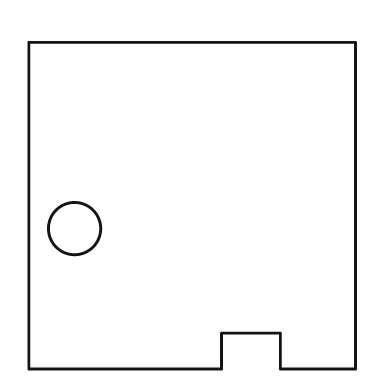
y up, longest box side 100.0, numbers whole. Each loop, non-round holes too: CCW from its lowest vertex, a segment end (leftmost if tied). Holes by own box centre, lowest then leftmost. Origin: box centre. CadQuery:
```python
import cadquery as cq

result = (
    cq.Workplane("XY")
    .moveTo(-50.0, -50.0)
    .lineTo(9.0, -50.0)
    .lineTo(9.0, -39.0)
    .lineTo(27.0, -39.0)
    .lineTo(27.0, -50.0)
    .lineTo(50.0, -50.0)
    .lineTo(50.0, 50.0)
    .lineTo(-50.0, 50.0)
    .close()
    .moveTo(-36.0, -7.0)
    .circle(8.0)
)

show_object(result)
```